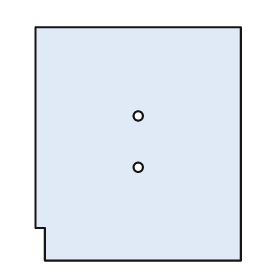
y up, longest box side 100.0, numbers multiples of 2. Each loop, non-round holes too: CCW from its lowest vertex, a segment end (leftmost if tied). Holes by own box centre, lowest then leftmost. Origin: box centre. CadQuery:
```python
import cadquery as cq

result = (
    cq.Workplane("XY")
    .moveTo(-40.0, -50.0)
    .lineTo(44.0, -50.0)
    .lineTo(44.0, 50.0)
    .lineTo(-44.0, 50.0)
    .lineTo(-44.0, -36.0)
    .lineTo(-40.0, -36.0)
    .close()
    .moveTo(0.0, -10.0)
    .circle(2.0)
    .moveTo(0.0, 12.0)
    .circle(2.0)
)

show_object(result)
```